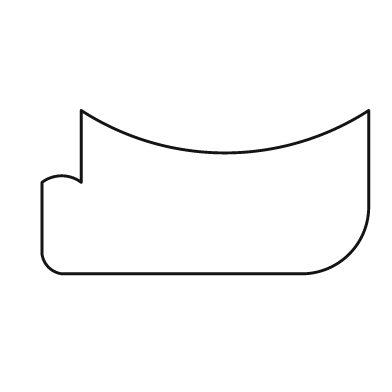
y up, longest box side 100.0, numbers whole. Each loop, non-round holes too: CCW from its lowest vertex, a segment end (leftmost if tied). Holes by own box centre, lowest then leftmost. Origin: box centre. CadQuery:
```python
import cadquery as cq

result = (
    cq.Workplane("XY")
    .moveTo(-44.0, -25.0)
    .lineTo(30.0, -25.0)
    .threePointArc((44.0, -19.0), (50.0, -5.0))
    .lineTo(50.0, 25.0)
    .threePointArc((6.0, 12.0), (-38.0, 25.0))
    .lineTo(-38.0, 3.0)
    .threePointArc((-44.0, 5.0), (-50.0, 3.0))
    .lineTo(-50.0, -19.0)
    .threePointArc((-48.0, -23.0), (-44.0, -25.0))
    .close()
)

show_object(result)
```